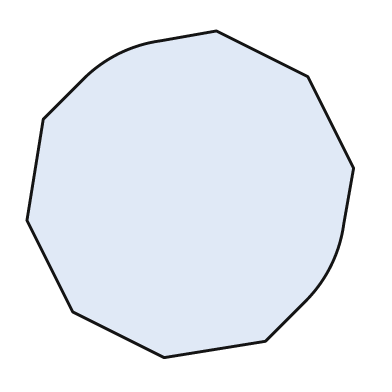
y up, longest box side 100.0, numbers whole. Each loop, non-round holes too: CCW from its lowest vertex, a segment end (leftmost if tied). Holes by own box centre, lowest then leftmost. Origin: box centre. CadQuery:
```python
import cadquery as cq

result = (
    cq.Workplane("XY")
    .moveTo(-8.0, -50.0)
    .lineTo(23.0, -45.0)
    .lineTo(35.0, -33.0)
    .threePointArc((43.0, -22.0), (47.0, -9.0))
    .lineTo(50.0, 8.0)
    .lineTo(36.0, 36.0)
    .lineTo(8.0, 50.0)
    .lineTo(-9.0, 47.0)
    .threePointArc((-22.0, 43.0), (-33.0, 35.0))
    .lineTo(-45.0, 23.0)
    .lineTo(-50.0, -8.0)
    .lineTo(-36.0, -36.0)
    .close()
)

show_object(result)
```